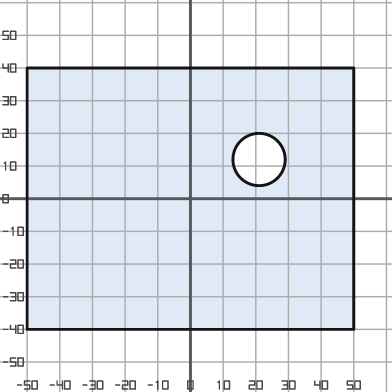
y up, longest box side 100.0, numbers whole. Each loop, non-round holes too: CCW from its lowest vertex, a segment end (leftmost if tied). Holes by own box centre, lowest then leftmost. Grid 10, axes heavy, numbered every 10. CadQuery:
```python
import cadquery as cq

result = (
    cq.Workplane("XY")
    .moveTo(-50.0, -40.0)
    .lineTo(50.0, -40.0)
    .lineTo(50.0, 40.0)
    .lineTo(-50.0, 40.0)
    .close()
    .moveTo(21.0, 12.0)
    .circle(8.0)
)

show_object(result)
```